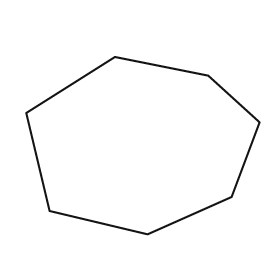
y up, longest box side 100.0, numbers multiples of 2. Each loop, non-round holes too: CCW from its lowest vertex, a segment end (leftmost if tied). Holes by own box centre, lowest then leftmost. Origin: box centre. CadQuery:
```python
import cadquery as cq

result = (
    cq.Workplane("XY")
    .moveTo(2.0, -38.0)
    .lineTo(38.0, -22.0)
    .lineTo(50.0, 10.0)
    .lineTo(28.0, 30.0)
    .lineTo(-12.0, 38.0)
    .lineTo(-50.0, 14.0)
    .lineTo(-40.0, -28.0)
    .close()
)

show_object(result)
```